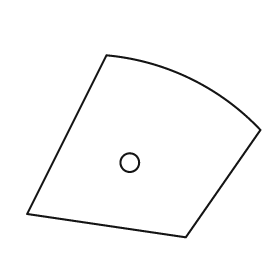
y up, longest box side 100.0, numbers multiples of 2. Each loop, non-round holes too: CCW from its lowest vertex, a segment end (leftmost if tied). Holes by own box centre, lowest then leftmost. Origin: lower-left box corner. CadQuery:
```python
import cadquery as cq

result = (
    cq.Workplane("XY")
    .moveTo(68.0, 0.0)
    .lineTo(100.0, 46.0)
    .threePointArc((70.0, 68.0), (34.0, 78.0))
    .lineTo(0.0, 10.0)
    .close()
    .moveTo(44.0, 32.0)
    .circle(4.0)
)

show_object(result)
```